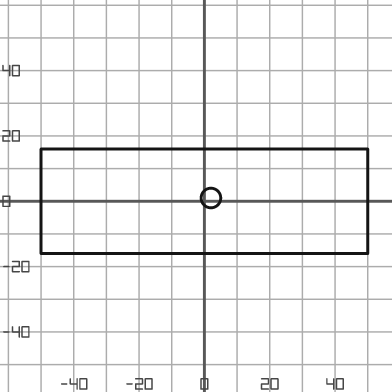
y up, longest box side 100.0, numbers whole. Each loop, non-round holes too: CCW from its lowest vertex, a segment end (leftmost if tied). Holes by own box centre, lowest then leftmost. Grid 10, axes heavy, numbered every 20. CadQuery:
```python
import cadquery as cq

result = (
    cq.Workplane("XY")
    .moveTo(-50.0, -16.0)
    .lineTo(50.0, -16.0)
    .lineTo(50.0, 16.0)
    .lineTo(-50.0, 16.0)
    .close()
    .moveTo(2.0, 1.0)
    .circle(3.0)
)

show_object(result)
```